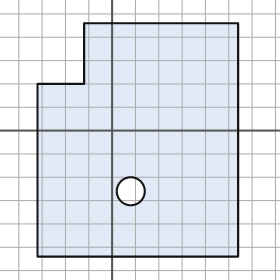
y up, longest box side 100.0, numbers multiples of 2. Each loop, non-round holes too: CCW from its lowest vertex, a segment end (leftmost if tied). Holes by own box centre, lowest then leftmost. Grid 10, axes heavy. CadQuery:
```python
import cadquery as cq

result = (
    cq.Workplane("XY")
    .moveTo(-32.0, -54.0)
    .lineTo(54.0, -54.0)
    .lineTo(54.0, 46.0)
    .lineTo(-12.0, 46.0)
    .lineTo(-12.0, 20.0)
    .lineTo(-32.0, 20.0)
    .close()
    .moveTo(8.0, -26.0)
    .circle(6.0)
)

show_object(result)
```